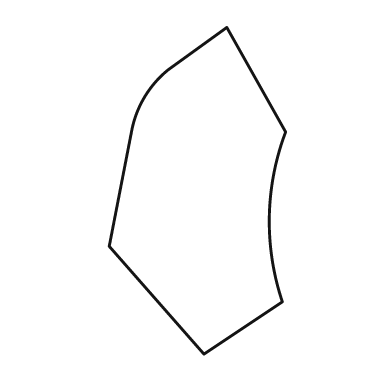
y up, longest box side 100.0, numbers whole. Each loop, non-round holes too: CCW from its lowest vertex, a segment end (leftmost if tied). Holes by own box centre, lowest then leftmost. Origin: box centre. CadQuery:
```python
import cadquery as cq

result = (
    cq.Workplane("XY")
    .moveTo(2.0, -50.0)
    .lineTo(26.0, -34.0)
    .threePointArc((22.0, -8.0), (27.0, 18.0))
    .lineTo(9.0, 50.0)
    .lineTo(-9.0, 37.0)
    .threePointArc((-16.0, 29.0), (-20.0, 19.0))
    .lineTo(-27.0, -17.0)
    .close()
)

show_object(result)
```